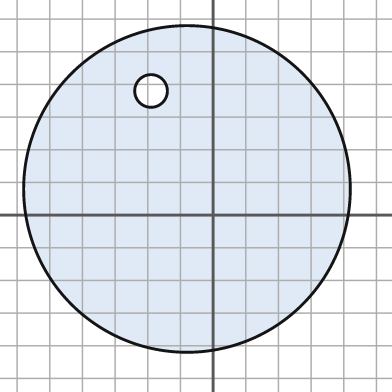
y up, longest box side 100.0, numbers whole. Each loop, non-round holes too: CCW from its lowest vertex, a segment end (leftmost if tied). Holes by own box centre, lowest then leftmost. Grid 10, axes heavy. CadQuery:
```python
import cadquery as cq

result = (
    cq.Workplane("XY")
    .moveTo(-8.0, 8.0)
    .circle(50.0)
    .moveTo(-19.0, 38.0)
    .circle(5.0)
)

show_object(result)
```